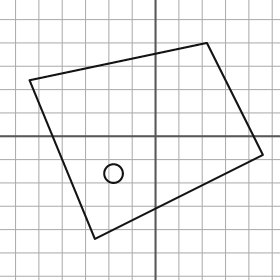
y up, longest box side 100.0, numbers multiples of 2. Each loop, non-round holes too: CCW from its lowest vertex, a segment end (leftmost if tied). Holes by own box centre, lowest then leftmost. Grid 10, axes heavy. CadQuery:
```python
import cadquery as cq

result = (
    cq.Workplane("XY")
    .moveTo(-26.0, -44.0)
    .lineTo(46.0, -8.0)
    .lineTo(22.0, 40.0)
    .lineTo(-54.0, 24.0)
    .close()
    .moveTo(-18.0, -16.0)
    .circle(4.0)
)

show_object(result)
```